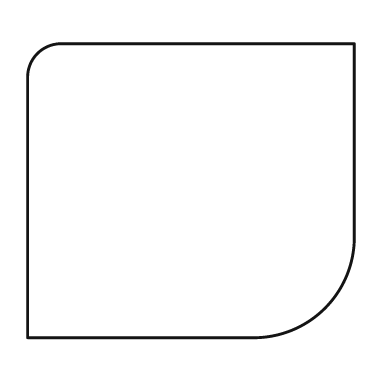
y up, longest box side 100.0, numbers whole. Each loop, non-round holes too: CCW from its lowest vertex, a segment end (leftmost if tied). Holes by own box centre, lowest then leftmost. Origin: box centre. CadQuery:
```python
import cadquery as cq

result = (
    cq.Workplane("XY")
    .moveTo(-50.0, -45.0)
    .lineTo(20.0, -45.0)
    .threePointArc((41.0, -36.0), (50.0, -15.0))
    .lineTo(50.0, 45.0)
    .lineTo(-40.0, 45.0)
    .threePointArc((-47.0, 42.0), (-50.0, 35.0))
    .close()
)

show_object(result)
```